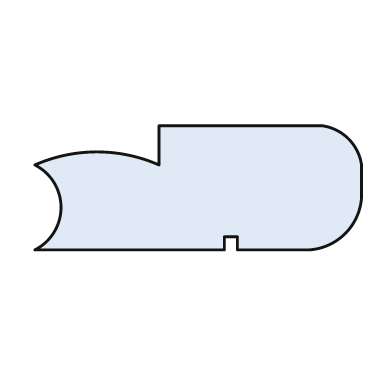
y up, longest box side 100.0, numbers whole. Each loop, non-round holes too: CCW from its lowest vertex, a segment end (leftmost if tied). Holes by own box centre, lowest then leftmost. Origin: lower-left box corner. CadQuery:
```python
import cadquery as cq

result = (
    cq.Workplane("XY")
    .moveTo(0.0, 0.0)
    .lineTo(58.0, 0.0)
    .lineTo(58.0, 4.0)
    .lineTo(62.0, 4.0)
    .lineTo(62.0, 0.0)
    .lineTo(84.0, 0.0)
    .threePointArc((95.0, 5.0), (100.0, 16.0))
    .lineTo(100.0, 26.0)
    .threePointArc((96.0, 34.0), (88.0, 38.0))
    .lineTo(38.0, 38.0)
    .lineTo(38.0, 26.0)
    .threePointArc((19.0, 30.0), (0.0, 26.0))
    .threePointArc((8.0, 13.0), (0.0, 0.0))
    .close()
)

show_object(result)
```